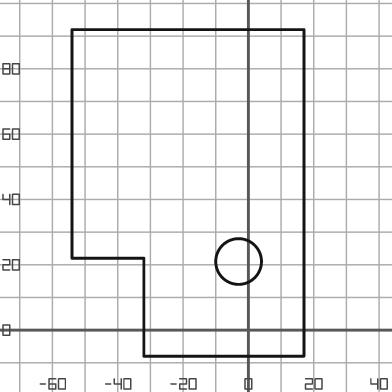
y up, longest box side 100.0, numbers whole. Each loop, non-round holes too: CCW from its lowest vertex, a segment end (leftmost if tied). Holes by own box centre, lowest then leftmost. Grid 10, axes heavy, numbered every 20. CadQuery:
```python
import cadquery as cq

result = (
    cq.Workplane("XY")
    .moveTo(-32.0, -8.0)
    .lineTo(17.0, -8.0)
    .lineTo(17.0, 92.0)
    .lineTo(-54.0, 92.0)
    .lineTo(-54.0, 22.0)
    .lineTo(-32.0, 22.0)
    .close()
    .moveTo(-3.0, 21.0)
    .circle(7.0)
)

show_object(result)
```